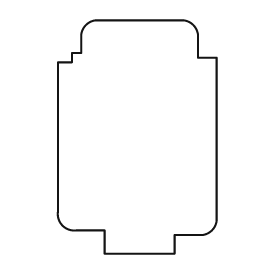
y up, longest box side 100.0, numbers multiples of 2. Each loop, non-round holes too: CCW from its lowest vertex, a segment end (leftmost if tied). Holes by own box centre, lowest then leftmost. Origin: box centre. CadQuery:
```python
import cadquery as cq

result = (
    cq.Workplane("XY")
    .moveTo(-14.0, -50.0)
    .lineTo(16.0, -50.0)
    .lineTo(16.0, -42.0)
    .lineTo(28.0, -42.0)
    .threePointArc((32.0, -40.0), (34.0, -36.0))
    .lineTo(34.0, 34.0)
    .lineTo(26.0, 34.0)
    .lineTo(26.0, 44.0)
    .threePointArc((24.0, 48.0), (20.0, 50.0))
    .lineTo(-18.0, 50.0)
    .threePointArc((-22.0, 48.0), (-24.0, 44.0))
    .lineTo(-24.0, 36.0)
    .lineTo(-28.0, 36.0)
    .lineTo(-28.0, 32.0)
    .lineTo(-34.0, 32.0)
    .lineTo(-34.0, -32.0)
    .threePointArc((-32.0, -38.0), (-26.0, -40.0))
    .lineTo(-14.0, -40.0)
    .close()
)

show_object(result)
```